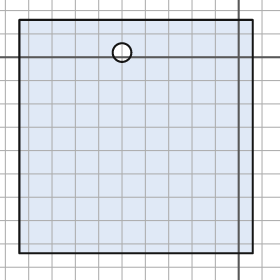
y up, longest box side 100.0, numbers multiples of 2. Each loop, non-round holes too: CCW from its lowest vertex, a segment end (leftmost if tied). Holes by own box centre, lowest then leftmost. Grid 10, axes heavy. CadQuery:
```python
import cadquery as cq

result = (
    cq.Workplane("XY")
    .moveTo(-94.0, -84.0)
    .lineTo(6.0, -84.0)
    .lineTo(6.0, 16.0)
    .lineTo(-94.0, 16.0)
    .close()
    .moveTo(-50.0, 2.0)
    .circle(4.0)
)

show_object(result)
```